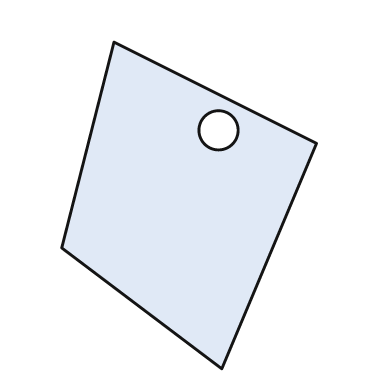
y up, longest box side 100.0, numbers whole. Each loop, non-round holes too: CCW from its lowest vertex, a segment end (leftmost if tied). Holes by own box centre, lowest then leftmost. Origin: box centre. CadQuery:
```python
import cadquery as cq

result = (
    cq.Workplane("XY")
    .moveTo(10.0, -50.0)
    .lineTo(39.0, 19.0)
    .lineTo(-23.0, 50.0)
    .lineTo(-39.0, -13.0)
    .close()
    .moveTo(9.0, 23.0)
    .circle(6.0)
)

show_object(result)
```